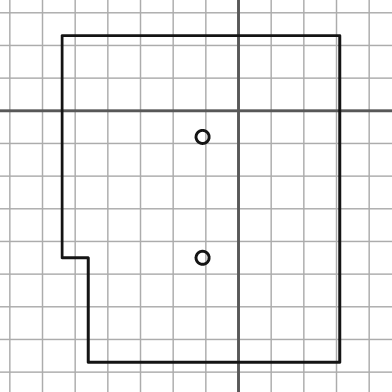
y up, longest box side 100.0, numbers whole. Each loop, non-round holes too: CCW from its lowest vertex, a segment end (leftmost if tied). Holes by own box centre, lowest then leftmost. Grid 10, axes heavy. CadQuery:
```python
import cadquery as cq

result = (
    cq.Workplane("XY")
    .moveTo(-46.0, -77.0)
    .lineTo(31.0, -77.0)
    .lineTo(31.0, 23.0)
    .lineTo(-54.0, 23.0)
    .lineTo(-54.0, -45.0)
    .lineTo(-46.0, -45.0)
    .close()
    .moveTo(-11.0, -45.0)
    .circle(2.0)
    .moveTo(-11.0, -8.0)
    .circle(2.0)
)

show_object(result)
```